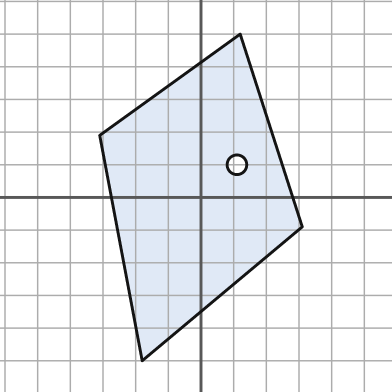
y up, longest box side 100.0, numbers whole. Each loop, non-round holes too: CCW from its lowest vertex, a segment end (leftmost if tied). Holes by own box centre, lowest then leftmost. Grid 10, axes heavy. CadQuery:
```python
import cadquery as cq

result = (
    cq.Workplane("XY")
    .moveTo(-18.0, -50.0)
    .lineTo(31.0, -9.0)
    .lineTo(12.0, 50.0)
    .lineTo(-31.0, 19.0)
    .close()
    .moveTo(11.0, 10.0)
    .circle(3.0)
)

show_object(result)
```